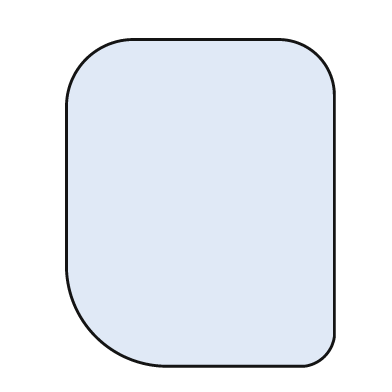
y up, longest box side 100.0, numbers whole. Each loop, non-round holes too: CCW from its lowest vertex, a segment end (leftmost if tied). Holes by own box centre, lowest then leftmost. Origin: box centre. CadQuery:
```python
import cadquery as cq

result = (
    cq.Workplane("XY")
    .moveTo(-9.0, -50.0)
    .lineTo(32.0, -50.0)
    .threePointArc((38.0, -47.0), (41.0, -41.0))
    .lineTo(41.0, 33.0)
    .threePointArc((36.0, 45.0), (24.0, 50.0))
    .lineTo(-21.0, 50.0)
    .threePointArc((-35.0, 44.0), (-41.0, 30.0))
    .lineTo(-41.0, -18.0)
    .threePointArc((-32.0, -41.0), (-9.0, -50.0))
    .close()
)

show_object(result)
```